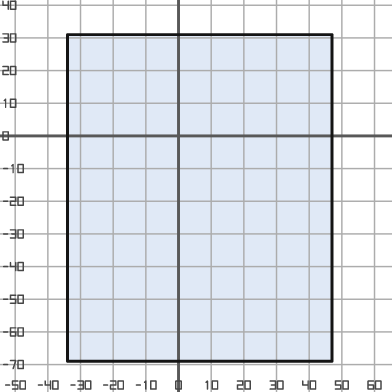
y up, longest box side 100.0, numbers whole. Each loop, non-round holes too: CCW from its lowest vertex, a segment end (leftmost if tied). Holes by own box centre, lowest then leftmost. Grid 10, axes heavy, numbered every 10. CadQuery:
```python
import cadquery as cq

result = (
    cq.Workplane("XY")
    .moveTo(-34.0, -69.0)
    .lineTo(47.0, -69.0)
    .lineTo(47.0, 31.0)
    .lineTo(-34.0, 31.0)
    .close()
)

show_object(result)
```